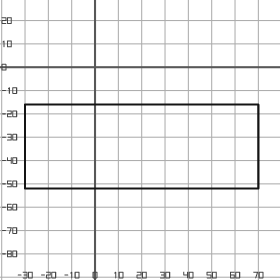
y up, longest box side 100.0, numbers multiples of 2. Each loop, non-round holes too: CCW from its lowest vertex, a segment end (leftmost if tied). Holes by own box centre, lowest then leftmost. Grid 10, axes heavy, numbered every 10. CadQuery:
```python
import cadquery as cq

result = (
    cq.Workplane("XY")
    .moveTo(-30.0, -52.0)
    .lineTo(70.0, -52.0)
    .lineTo(70.0, -16.0)
    .lineTo(-30.0, -16.0)
    .close()
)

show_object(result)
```